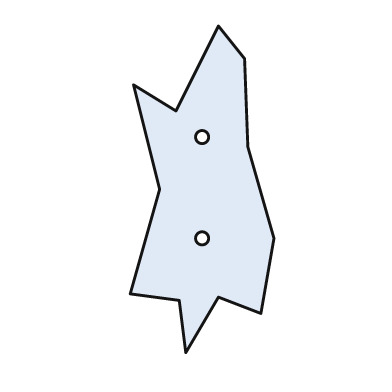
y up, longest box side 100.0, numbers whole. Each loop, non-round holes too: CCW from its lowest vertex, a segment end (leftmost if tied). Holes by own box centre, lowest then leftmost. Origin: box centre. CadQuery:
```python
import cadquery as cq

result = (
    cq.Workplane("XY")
    .moveTo(-5.0, -50.0)
    .lineTo(5.0, -33.0)
    .lineTo(18.0, -38.0)
    .lineTo(22.0, -15.0)
    .lineTo(14.0, 13.0)
    .lineTo(13.0, 40.0)
    .lineTo(5.0, 50.0)
    .lineTo(-8.0, 24.0)
    .lineTo(-21.0, 32.0)
    .lineTo(-13.0, 0.0)
    .lineTo(-22.0, -32.0)
    .lineTo(-7.0, -34.0)
    .close()
    .moveTo(0.0, -15.0)
    .circle(2.0)
    .moveTo(0.0, 16.0)
    .circle(2.0)
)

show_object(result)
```